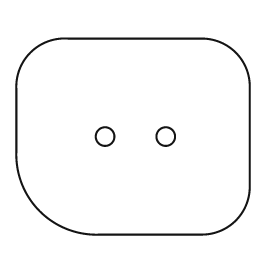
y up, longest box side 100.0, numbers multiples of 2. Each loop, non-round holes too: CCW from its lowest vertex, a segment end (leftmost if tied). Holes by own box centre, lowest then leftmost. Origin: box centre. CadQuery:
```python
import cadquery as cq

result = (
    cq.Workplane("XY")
    .moveTo(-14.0, -42.0)
    .lineTo(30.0, -42.0)
    .threePointArc((44.0, -36.0), (50.0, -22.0))
    .lineTo(50.0, 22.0)
    .threePointArc((44.0, 36.0), (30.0, 42.0))
    .lineTo(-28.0, 42.0)
    .threePointArc((-44.0, 36.0), (-50.0, 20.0))
    .lineTo(-50.0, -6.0)
    .threePointArc((-40.0, -32.0), (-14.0, -42.0))
    .close()
    .moveTo(-12.0, 0.0)
    .circle(4.0)
    .moveTo(14.0, 0.0)
    .circle(4.0)
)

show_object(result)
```